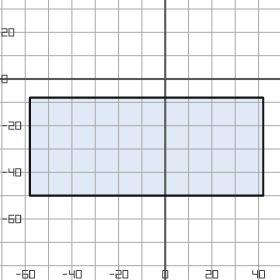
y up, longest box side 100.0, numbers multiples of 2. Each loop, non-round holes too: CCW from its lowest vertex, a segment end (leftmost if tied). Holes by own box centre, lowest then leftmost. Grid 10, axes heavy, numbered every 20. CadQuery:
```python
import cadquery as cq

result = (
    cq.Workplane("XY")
    .moveTo(-58.0, -50.0)
    .lineTo(42.0, -50.0)
    .lineTo(42.0, -8.0)
    .lineTo(-58.0, -8.0)
    .close()
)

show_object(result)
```